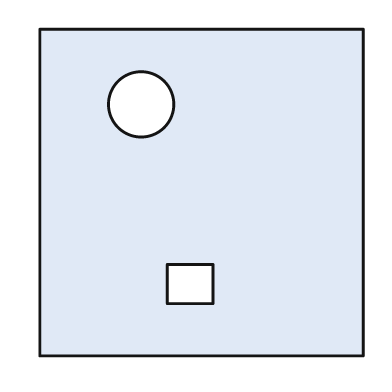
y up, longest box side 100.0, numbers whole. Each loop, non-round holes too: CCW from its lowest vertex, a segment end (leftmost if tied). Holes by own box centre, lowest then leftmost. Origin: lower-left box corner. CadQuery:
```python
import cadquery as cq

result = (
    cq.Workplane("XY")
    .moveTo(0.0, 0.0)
    .lineTo(99.0, 0.0)
    .lineTo(99.0, 100.0)
    .lineTo(0.0, 100.0)
    .close()
    .moveTo(39.0, 16.0)
    .lineTo(53.0, 16.0)
    .lineTo(53.0, 28.0)
    .lineTo(39.0, 28.0)
    .close()
    .moveTo(31.0, 77.0)
    .circle(10.0)
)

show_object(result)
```